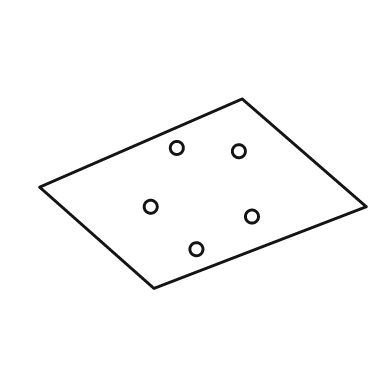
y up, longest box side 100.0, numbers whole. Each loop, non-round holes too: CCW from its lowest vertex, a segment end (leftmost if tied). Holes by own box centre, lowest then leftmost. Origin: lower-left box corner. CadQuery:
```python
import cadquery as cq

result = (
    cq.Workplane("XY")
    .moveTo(35.0, 0.0)
    .lineTo(100.0, 25.0)
    .lineTo(62.0, 58.0)
    .lineTo(0.0, 31.0)
    .close()
    .moveTo(48.0, 12.0)
    .circle(2.0)
    .moveTo(65.0, 22.0)
    .circle(2.0)
    .moveTo(34.0, 25.0)
    .circle(2.0)
    .moveTo(61.0, 42.0)
    .circle(2.0)
    .moveTo(42.0, 43.0)
    .circle(2.0)
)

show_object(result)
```